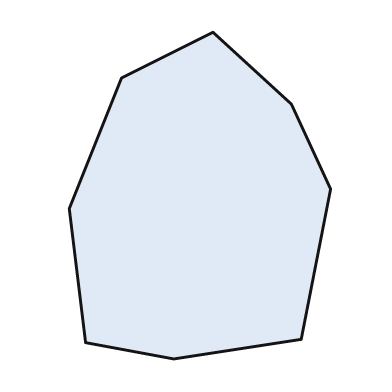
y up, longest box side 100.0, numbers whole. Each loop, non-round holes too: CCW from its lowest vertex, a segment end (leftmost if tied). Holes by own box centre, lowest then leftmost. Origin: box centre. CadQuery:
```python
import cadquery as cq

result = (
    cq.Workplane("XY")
    .moveTo(-8.0, -50.0)
    .lineTo(31.0, -44.0)
    .lineTo(40.0, 2.0)
    .lineTo(28.0, 28.0)
    .lineTo(4.0, 50.0)
    .lineTo(-24.0, 36.0)
    .lineTo(-40.0, -4.0)
    .lineTo(-35.0, -45.0)
    .close()
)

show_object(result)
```